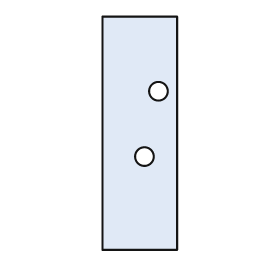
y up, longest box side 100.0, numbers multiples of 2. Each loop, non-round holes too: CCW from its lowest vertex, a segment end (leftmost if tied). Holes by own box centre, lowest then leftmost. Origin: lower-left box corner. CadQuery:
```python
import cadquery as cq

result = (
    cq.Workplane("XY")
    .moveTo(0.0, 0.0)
    .lineTo(32.0, 0.0)
    .lineTo(32.0, 100.0)
    .lineTo(0.0, 100.0)
    .close()
    .moveTo(18.0, 40.0)
    .circle(4.0)
    .moveTo(24.0, 68.0)
    .circle(4.0)
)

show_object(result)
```